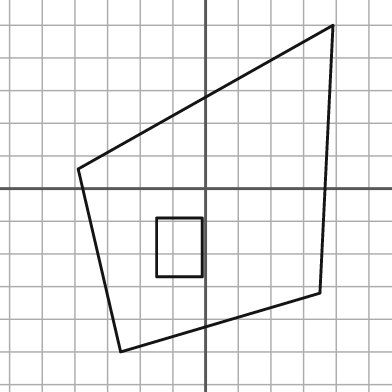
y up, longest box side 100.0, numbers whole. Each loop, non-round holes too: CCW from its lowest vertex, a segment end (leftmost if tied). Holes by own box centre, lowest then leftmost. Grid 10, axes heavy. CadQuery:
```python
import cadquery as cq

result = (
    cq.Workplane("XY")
    .moveTo(-26.0, -50.0)
    .lineTo(35.0, -32.0)
    .lineTo(39.0, 50.0)
    .lineTo(-39.0, 6.0)
    .close()
    .moveTo(-15.0, -27.0)
    .lineTo(-1.0, -27.0)
    .lineTo(-1.0, -9.0)
    .lineTo(-15.0, -9.0)
    .close()
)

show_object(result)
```